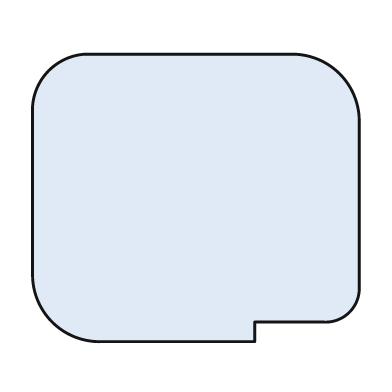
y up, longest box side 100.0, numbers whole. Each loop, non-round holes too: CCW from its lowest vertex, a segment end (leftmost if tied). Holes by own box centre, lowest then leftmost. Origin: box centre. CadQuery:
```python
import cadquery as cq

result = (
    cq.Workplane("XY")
    .moveTo(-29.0, -44.0)
    .lineTo(18.0, -44.0)
    .lineTo(18.0, -38.0)
    .lineTo(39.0, -38.0)
    .threePointArc((47.0, -35.0), (50.0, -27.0))
    .lineTo(50.0, 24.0)
    .threePointArc((44.0, 38.0), (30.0, 44.0))
    .lineTo(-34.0, 44.0)
    .threePointArc((-45.0, 39.0), (-50.0, 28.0))
    .lineTo(-50.0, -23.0)
    .threePointArc((-44.0, -38.0), (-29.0, -44.0))
    .close()
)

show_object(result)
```